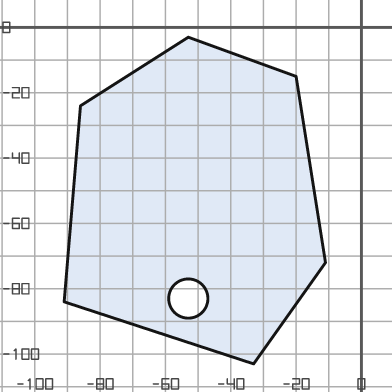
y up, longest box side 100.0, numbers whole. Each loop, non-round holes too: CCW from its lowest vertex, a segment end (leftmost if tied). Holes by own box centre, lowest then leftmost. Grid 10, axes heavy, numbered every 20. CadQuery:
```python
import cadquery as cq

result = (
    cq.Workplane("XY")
    .moveTo(-33.0, -103.0)
    .lineTo(-11.0, -72.0)
    .lineTo(-20.0, -15.0)
    .lineTo(-53.0, -3.0)
    .lineTo(-86.0, -24.0)
    .lineTo(-91.0, -84.0)
    .close()
    .moveTo(-53.0, -83.0)
    .circle(6.0)
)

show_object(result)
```